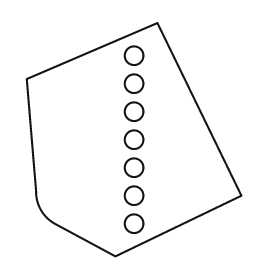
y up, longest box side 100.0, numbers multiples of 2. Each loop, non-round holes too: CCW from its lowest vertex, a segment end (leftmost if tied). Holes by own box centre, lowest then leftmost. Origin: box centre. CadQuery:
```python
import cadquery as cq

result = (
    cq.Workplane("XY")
    .moveTo(-8.0, -50.0)
    .lineTo(46.0, -24.0)
    .lineTo(10.0, 50.0)
    .lineTo(-46.0, 26.0)
    .lineTo(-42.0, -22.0)
    .threePointArc((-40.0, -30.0), (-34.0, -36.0))
    .close()
    .moveTo(0.0, -36.0)
    .circle(4.0)
    .moveTo(0.0, -24.0)
    .circle(4.0)
    .moveTo(0.0, -12.0)
    .circle(4.0)
    .moveTo(0.0, 0.0)
    .circle(4.0)
    .moveTo(0.0, 12.0)
    .circle(4.0)
    .moveTo(0.0, 24.0)
    .circle(4.0)
    .moveTo(0.0, 36.0)
    .circle(4.0)
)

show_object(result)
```